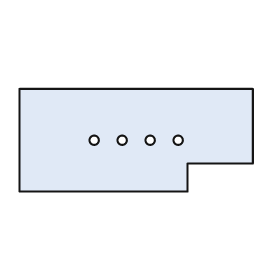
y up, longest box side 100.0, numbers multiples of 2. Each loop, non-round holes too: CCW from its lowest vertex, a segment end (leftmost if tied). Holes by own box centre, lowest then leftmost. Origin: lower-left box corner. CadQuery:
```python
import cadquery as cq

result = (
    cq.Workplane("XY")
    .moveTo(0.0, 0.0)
    .lineTo(72.0, 0.0)
    .lineTo(72.0, 12.0)
    .lineTo(100.0, 12.0)
    .lineTo(100.0, 44.0)
    .lineTo(0.0, 44.0)
    .close()
    .moveTo(32.0, 22.0)
    .circle(2.0)
    .moveTo(44.0, 22.0)
    .circle(2.0)
    .moveTo(56.0, 22.0)
    .circle(2.0)
    .moveTo(68.0, 22.0)
    .circle(2.0)
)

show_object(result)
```